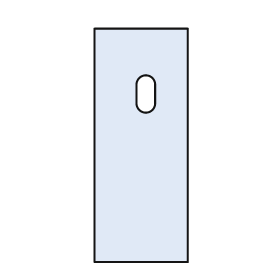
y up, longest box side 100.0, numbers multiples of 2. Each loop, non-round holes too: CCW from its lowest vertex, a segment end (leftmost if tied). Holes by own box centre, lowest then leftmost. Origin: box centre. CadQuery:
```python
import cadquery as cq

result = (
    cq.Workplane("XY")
    .moveTo(-20.0, -50.0)
    .lineTo(20.0, -50.0)
    .lineTo(20.0, 50.0)
    .lineTo(-20.0, 50.0)
    .close()
    .moveTo(-2.0, 18.0)
    .threePointArc((2.0, 14.0), (6.0, 18.0))
    .lineTo(6.0, 26.0)
    .threePointArc((2.0, 30.0), (-2.0, 26.0))
    .close()
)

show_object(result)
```